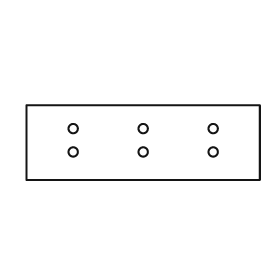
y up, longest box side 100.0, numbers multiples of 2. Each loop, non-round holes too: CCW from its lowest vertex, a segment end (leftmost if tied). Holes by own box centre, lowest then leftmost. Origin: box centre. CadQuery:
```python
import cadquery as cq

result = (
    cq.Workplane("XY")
    .moveTo(-50.0, -16.0)
    .lineTo(50.0, -16.0)
    .lineTo(50.0, 16.0)
    .lineTo(-50.0, 16.0)
    .close()
    .moveTo(-30.0, -4.0)
    .circle(2.0)
    .moveTo(0.0, -4.0)
    .circle(2.0)
    .moveTo(30.0, -4.0)
    .circle(2.0)
    .moveTo(-30.0, 6.0)
    .circle(2.0)
    .moveTo(0.0, 6.0)
    .circle(2.0)
    .moveTo(30.0, 6.0)
    .circle(2.0)
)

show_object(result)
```